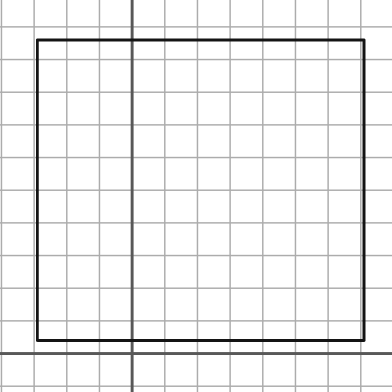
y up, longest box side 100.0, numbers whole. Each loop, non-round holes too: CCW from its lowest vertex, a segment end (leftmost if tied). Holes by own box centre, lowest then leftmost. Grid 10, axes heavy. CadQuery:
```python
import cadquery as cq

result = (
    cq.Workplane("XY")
    .moveTo(-29.0, 4.0)
    .lineTo(71.0, 4.0)
    .lineTo(71.0, 96.0)
    .lineTo(-29.0, 96.0)
    .close()
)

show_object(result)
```